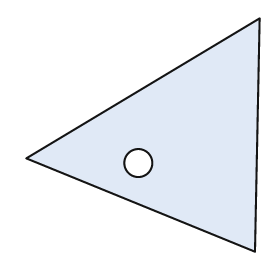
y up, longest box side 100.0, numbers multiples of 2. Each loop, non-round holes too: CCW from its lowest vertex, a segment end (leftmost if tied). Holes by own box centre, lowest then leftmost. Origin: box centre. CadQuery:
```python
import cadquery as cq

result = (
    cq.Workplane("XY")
    .moveTo(48.0, -50.0)
    .lineTo(50.0, 50.0)
    .lineTo(-50.0, -10.0)
    .close()
    .moveTo(-2.0, -12.0)
    .circle(6.0)
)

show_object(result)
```